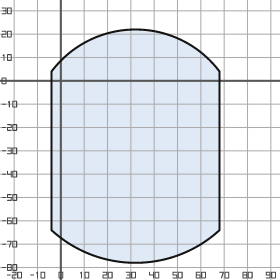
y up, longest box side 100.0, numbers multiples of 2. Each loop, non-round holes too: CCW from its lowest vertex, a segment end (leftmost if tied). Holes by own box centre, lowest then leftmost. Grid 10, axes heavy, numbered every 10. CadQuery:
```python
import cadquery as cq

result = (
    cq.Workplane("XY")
    .moveTo(-4.0, -64.0)
    .threePointArc((32.0, -78.0), (68.0, -64.0))
    .lineTo(68.0, 4.0)
    .threePointArc((32.0, 22.0), (-4.0, 4.0))
    .close()
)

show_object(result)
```